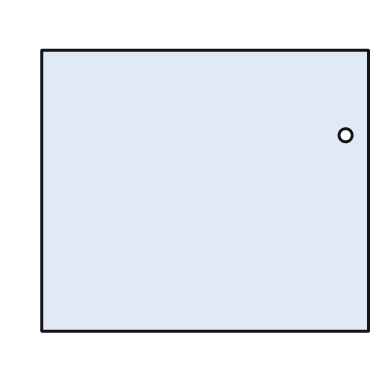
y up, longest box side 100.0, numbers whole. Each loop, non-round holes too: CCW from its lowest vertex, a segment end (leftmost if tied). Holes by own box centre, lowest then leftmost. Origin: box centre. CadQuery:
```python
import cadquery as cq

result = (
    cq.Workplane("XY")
    .moveTo(-50.0, -43.0)
    .lineTo(50.0, -43.0)
    .lineTo(50.0, 43.0)
    .lineTo(-50.0, 43.0)
    .close()
    .moveTo(43.0, 17.0)
    .circle(2.0)
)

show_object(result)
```